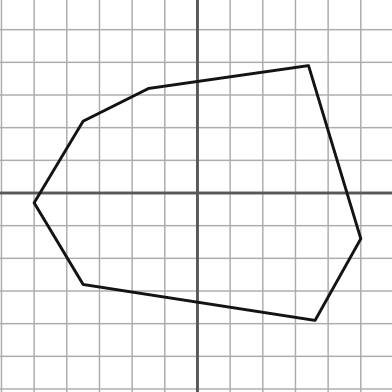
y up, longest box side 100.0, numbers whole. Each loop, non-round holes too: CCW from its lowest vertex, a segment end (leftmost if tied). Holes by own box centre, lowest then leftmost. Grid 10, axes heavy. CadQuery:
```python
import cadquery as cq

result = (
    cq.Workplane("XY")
    .moveTo(36.0, -39.0)
    .lineTo(50.0, -14.0)
    .lineTo(34.0, 39.0)
    .lineTo(-15.0, 32.0)
    .lineTo(-35.0, 22.0)
    .lineTo(-50.0, -3.0)
    .lineTo(-35.0, -28.0)
    .close()
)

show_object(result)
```